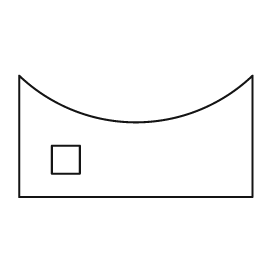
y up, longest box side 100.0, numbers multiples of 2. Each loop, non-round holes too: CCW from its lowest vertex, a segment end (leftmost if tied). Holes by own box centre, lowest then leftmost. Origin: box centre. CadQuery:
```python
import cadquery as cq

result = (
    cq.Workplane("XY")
    .moveTo(-50.0, -26.0)
    .lineTo(50.0, -26.0)
    .lineTo(50.0, 26.0)
    .threePointArc((0.0, 6.0), (-50.0, 26.0))
    .close()
    .moveTo(-36.0, -16.0)
    .lineTo(-24.0, -16.0)
    .lineTo(-24.0, -4.0)
    .lineTo(-36.0, -4.0)
    .close()
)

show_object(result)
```